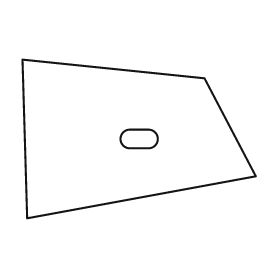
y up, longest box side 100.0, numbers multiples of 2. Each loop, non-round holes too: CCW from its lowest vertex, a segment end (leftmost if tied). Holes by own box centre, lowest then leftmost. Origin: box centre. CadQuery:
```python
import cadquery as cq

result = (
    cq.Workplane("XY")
    .moveTo(-48.0, -34.0)
    .lineTo(50.0, -16.0)
    .lineTo(28.0, 26.0)
    .lineTo(-50.0, 34.0)
    .close()
    .moveTo(-4.0, -4.0)
    .lineTo(4.0, -4.0)
    .threePointArc((8.0, 0.0), (4.0, 4.0))
    .lineTo(-4.0, 4.0)
    .threePointArc((-8.0, 0.0), (-4.0, -4.0))
    .close()
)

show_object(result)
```